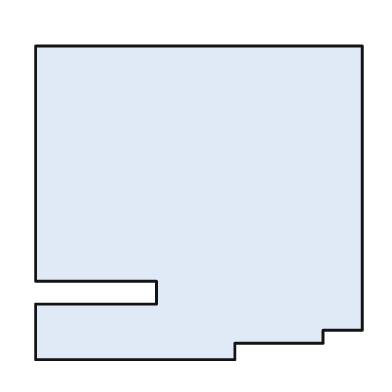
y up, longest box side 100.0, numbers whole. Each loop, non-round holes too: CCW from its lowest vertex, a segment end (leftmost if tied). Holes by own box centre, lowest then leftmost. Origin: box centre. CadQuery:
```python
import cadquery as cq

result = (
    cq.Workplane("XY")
    .moveTo(-50.0, -48.0)
    .lineTo(11.0, -48.0)
    .lineTo(11.0, -43.0)
    .lineTo(38.0, -43.0)
    .lineTo(38.0, -39.0)
    .lineTo(50.0, -39.0)
    .lineTo(50.0, 48.0)
    .lineTo(-50.0, 48.0)
    .lineTo(-50.0, -24.0)
    .lineTo(-13.0, -24.0)
    .lineTo(-13.0, -31.0)
    .lineTo(-50.0, -31.0)
    .close()
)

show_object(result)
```